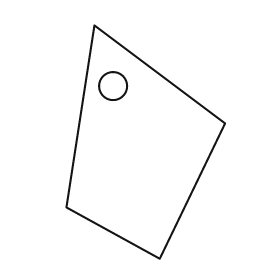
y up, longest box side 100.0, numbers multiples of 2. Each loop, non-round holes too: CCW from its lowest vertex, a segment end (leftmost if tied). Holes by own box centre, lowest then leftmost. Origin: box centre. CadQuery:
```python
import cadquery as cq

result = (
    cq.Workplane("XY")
    .moveTo(6.0, -50.0)
    .lineTo(34.0, 8.0)
    .lineTo(-22.0, 50.0)
    .lineTo(-34.0, -28.0)
    .close()
    .moveTo(-14.0, 24.0)
    .circle(6.0)
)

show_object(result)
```